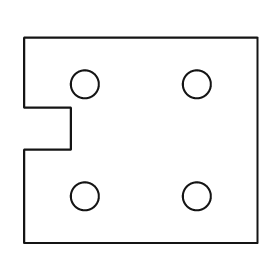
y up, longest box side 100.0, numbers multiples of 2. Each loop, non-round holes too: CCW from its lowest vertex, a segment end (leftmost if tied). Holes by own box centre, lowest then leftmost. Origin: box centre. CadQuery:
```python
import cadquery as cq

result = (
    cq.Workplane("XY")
    .moveTo(-50.0, -44.0)
    .lineTo(50.0, -44.0)
    .lineTo(50.0, 44.0)
    .lineTo(-50.0, 44.0)
    .lineTo(-50.0, 14.0)
    .lineTo(-30.0, 14.0)
    .lineTo(-30.0, -4.0)
    .lineTo(-50.0, -4.0)
    .close()
    .moveTo(-24.0, -24.0)
    .circle(6.0)
    .moveTo(24.0, -24.0)
    .circle(6.0)
    .moveTo(-24.0, 24.0)
    .circle(6.0)
    .moveTo(24.0, 24.0)
    .circle(6.0)
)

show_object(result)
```